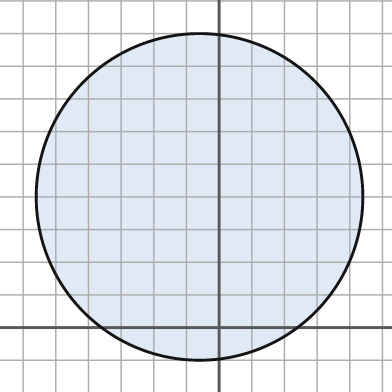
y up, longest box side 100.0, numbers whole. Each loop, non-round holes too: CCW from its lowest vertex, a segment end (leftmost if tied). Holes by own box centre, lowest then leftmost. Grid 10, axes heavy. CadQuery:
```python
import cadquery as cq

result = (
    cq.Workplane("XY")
    .moveTo(-6.0, 40.0)
    .circle(50.0)
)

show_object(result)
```